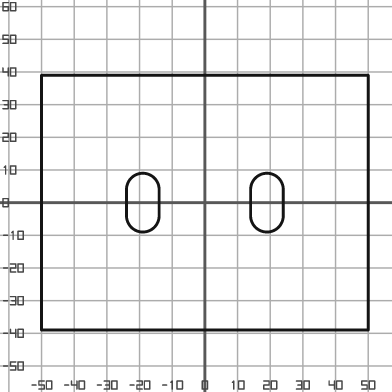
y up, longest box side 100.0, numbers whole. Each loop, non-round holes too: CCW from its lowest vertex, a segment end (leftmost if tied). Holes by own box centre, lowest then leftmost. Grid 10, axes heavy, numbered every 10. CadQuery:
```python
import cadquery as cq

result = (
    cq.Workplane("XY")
    .moveTo(-50.0, -39.0)
    .lineTo(50.0, -39.0)
    .lineTo(50.0, 39.0)
    .lineTo(-50.0, 39.0)
    .close()
    .moveTo(-24.0, -4.0)
    .threePointArc((-19.0, -9.0), (-14.0, -4.0))
    .lineTo(-14.0, 4.0)
    .threePointArc((-19.0, 9.0), (-24.0, 4.0))
    .close()
    .moveTo(14.0, -4.0)
    .threePointArc((19.0, -9.0), (24.0, -4.0))
    .lineTo(24.0, 4.0)
    .threePointArc((19.0, 9.0), (14.0, 4.0))
    .close()
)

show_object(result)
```